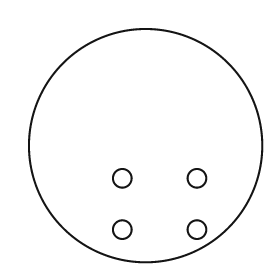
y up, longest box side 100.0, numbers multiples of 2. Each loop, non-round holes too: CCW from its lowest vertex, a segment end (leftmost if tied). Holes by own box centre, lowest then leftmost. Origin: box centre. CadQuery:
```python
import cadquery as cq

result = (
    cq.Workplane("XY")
    .moveTo(0.0, 0.0)
    .circle(50.0)
    .moveTo(-10.0, -36.0)
    .circle(4.0)
    .moveTo(22.0, -36.0)
    .circle(4.0)
    .moveTo(-10.0, -14.0)
    .circle(4.0)
    .moveTo(22.0, -14.0)
    .circle(4.0)
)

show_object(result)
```